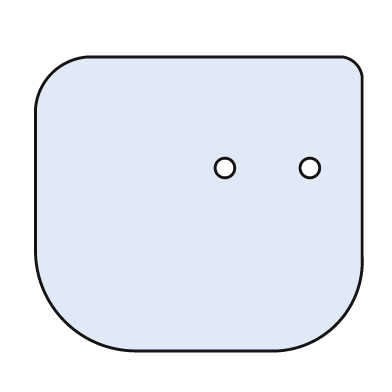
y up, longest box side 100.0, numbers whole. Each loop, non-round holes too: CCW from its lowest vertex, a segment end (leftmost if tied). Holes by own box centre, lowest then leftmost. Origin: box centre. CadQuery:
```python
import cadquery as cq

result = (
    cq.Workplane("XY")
    .moveTo(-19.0, -45.0)
    .lineTo(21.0, -45.0)
    .threePointArc((42.0, -37.0), (50.0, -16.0))
    .lineTo(50.0, 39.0)
    .threePointArc((48.0, 43.0), (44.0, 45.0))
    .lineTo(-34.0, 45.0)
    .threePointArc((-45.0, 40.0), (-50.0, 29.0))
    .lineTo(-50.0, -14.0)
    .threePointArc((-41.0, -36.0), (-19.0, -45.0))
    .close()
    .moveTo(8.0, 11.0)
    .circle(3.0)
    .moveTo(34.0, 11.0)
    .circle(3.0)
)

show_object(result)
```